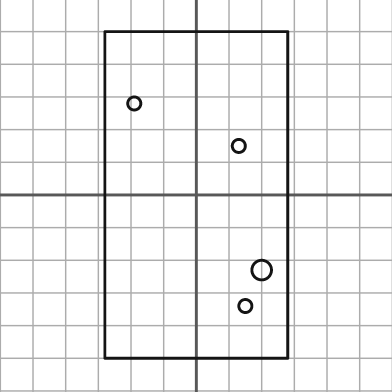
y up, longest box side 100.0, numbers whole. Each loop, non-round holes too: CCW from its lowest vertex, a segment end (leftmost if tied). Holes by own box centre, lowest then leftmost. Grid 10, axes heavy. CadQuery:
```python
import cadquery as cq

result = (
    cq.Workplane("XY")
    .moveTo(-28.0, -50.0)
    .lineTo(28.0, -50.0)
    .lineTo(28.0, 50.0)
    .lineTo(-28.0, 50.0)
    .close()
    .moveTo(15.0, -34.0)
    .circle(2.0)
    .moveTo(20.0, -23.0)
    .circle(3.0)
    .moveTo(13.0, 15.0)
    .circle(2.0)
    .moveTo(-19.0, 28.0)
    .circle(2.0)
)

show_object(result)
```